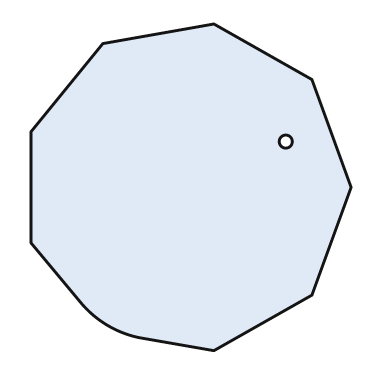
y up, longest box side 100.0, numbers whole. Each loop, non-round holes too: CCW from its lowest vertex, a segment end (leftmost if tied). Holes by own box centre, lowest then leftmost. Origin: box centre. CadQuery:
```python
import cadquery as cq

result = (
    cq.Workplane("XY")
    .moveTo(7.0, -50.0)
    .lineTo(37.0, -33.0)
    .lineTo(49.0, 0.0)
    .lineTo(37.0, 33.0)
    .lineTo(7.0, 50.0)
    .lineTo(-27.0, 44.0)
    .lineTo(-49.0, 17.0)
    .lineTo(-49.0, -17.0)
    .lineTo(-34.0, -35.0)
    .threePointArc((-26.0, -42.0), (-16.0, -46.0))
    .close()
    .moveTo(29.0, 14.0)
    .circle(2.0)
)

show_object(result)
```